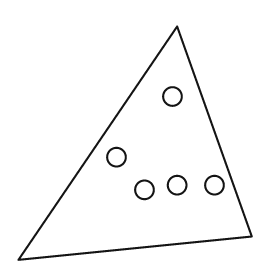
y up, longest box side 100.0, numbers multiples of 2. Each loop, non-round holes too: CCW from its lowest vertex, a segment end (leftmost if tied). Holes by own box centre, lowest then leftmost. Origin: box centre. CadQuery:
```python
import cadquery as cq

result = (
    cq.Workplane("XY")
    .moveTo(-50.0, -50.0)
    .lineTo(50.0, -40.0)
    .lineTo(18.0, 50.0)
    .close()
    .moveTo(4.0, -20.0)
    .circle(4.0)
    .moveTo(18.0, -18.0)
    .circle(4.0)
    .moveTo(34.0, -18.0)
    .circle(4.0)
    .moveTo(-8.0, -6.0)
    .circle(4.0)
    .moveTo(16.0, 20.0)
    .circle(4.0)
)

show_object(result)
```